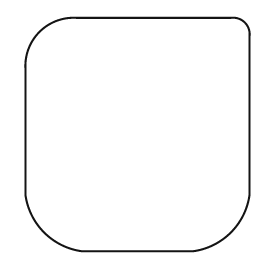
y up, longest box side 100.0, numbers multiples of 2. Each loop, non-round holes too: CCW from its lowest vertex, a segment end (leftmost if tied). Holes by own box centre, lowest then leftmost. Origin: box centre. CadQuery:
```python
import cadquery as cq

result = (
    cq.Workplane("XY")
    .moveTo(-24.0, -50.0)
    .lineTo(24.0, -50.0)
    .threePointArc((40.0, -42.0), (48.0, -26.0))
    .lineTo(48.0, 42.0)
    .threePointArc((46.0, 48.0), (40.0, 50.0))
    .lineTo(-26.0, 50.0)
    .threePointArc((-42.0, 44.0), (-48.0, 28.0))
    .lineTo(-48.0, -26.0)
    .threePointArc((-40.0, -42.0), (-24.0, -50.0))
    .close()
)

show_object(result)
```